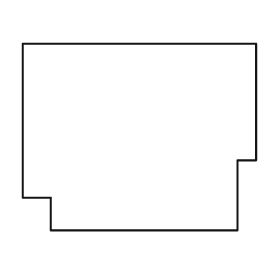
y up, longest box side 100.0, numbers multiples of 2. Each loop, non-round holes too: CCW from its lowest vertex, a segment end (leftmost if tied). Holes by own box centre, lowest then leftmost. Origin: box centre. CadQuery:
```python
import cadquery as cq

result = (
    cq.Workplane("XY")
    .moveTo(-38.0, -40.0)
    .lineTo(42.0, -40.0)
    .lineTo(42.0, -10.0)
    .lineTo(50.0, -10.0)
    .lineTo(50.0, 40.0)
    .lineTo(-50.0, 40.0)
    .lineTo(-50.0, -26.0)
    .lineTo(-38.0, -26.0)
    .close()
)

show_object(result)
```